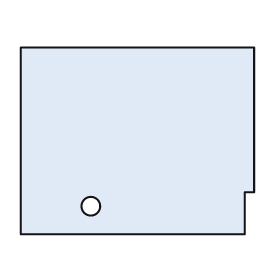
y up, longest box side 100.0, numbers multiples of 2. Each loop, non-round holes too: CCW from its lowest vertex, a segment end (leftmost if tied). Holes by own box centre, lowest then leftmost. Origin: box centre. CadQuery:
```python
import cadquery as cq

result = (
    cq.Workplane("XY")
    .moveTo(-50.0, -40.0)
    .lineTo(46.0, -40.0)
    .lineTo(46.0, -22.0)
    .lineTo(50.0, -22.0)
    .lineTo(50.0, 40.0)
    .lineTo(-50.0, 40.0)
    .close()
    .moveTo(-20.0, -28.0)
    .circle(4.0)
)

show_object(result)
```